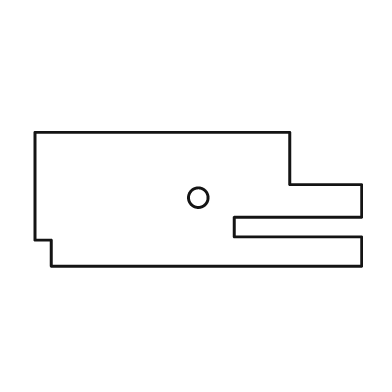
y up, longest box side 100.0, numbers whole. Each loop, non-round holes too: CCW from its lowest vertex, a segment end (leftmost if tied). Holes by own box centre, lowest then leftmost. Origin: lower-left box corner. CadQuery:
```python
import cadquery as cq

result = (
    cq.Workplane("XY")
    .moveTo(5.0, 0.0)
    .lineTo(100.0, 0.0)
    .lineTo(100.0, 9.0)
    .lineTo(61.0, 9.0)
    .lineTo(61.0, 15.0)
    .lineTo(100.0, 15.0)
    .lineTo(100.0, 25.0)
    .lineTo(78.0, 25.0)
    .lineTo(78.0, 41.0)
    .lineTo(0.0, 41.0)
    .lineTo(0.0, 8.0)
    .lineTo(5.0, 8.0)
    .close()
    .moveTo(50.0, 21.0)
    .circle(3.0)
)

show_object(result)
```